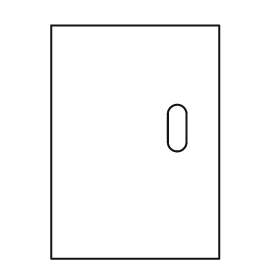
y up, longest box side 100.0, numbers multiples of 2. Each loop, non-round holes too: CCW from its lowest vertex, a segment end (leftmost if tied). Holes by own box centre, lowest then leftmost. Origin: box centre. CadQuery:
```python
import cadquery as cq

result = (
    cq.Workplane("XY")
    .moveTo(-36.0, -50.0)
    .lineTo(36.0, -50.0)
    .lineTo(36.0, 50.0)
    .lineTo(-36.0, 50.0)
    .close()
    .moveTo(14.0, 0.0)
    .threePointArc((18.0, -4.0), (22.0, 0.0))
    .lineTo(22.0, 12.0)
    .threePointArc((18.0, 16.0), (14.0, 12.0))
    .close()
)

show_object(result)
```